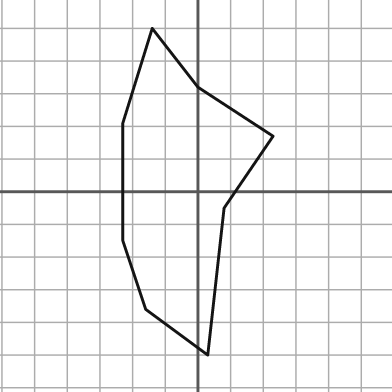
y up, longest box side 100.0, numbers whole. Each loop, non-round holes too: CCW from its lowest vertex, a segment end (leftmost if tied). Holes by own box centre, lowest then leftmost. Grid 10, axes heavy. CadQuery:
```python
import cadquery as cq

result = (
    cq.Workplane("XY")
    .moveTo(3.0, -50.0)
    .lineTo(8.0, -5.0)
    .lineTo(23.0, 17.0)
    .lineTo(0.0, 32.0)
    .lineTo(-14.0, 50.0)
    .lineTo(-23.0, 21.0)
    .lineTo(-23.0, -15.0)
    .lineTo(-16.0, -36.0)
    .close()
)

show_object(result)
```